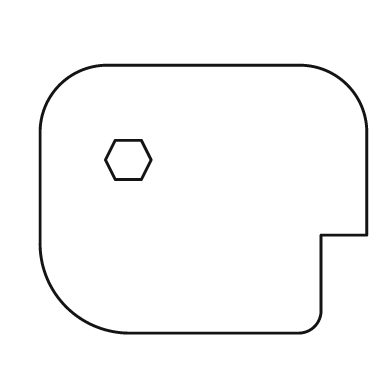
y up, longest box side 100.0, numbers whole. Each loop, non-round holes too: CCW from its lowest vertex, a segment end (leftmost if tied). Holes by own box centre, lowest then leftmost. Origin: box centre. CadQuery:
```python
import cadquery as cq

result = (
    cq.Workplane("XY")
    .moveTo(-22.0, -41.0)
    .lineTo(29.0, -41.0)
    .threePointArc((34.0, -39.0), (36.0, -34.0))
    .lineTo(36.0, -11.0)
    .lineTo(50.0, -11.0)
    .lineTo(50.0, 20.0)
    .threePointArc((44.0, 35.0), (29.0, 41.0))
    .lineTo(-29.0, 41.0)
    .threePointArc((-44.0, 35.0), (-50.0, 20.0))
    .lineTo(-50.0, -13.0)
    .threePointArc((-42.0, -33.0), (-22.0, -41.0))
    .close()
    .moveTo(-27.0, 6.0)
    .lineTo(-19.0, 6.0)
    .lineTo(-16.0, 12.0)
    .lineTo(-19.0, 18.0)
    .lineTo(-27.0, 18.0)
    .lineTo(-30.0, 12.0)
    .close()
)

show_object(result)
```